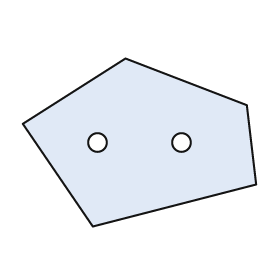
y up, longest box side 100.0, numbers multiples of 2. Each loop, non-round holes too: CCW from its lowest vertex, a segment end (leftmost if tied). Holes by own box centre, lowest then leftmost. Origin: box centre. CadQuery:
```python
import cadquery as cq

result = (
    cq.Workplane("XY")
    .moveTo(-20.0, -36.0)
    .lineTo(50.0, -18.0)
    .lineTo(46.0, 16.0)
    .lineTo(-6.0, 36.0)
    .lineTo(-50.0, 8.0)
    .close()
    .moveTo(-18.0, 0.0)
    .circle(4.0)
    .moveTo(18.0, 0.0)
    .circle(4.0)
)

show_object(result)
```